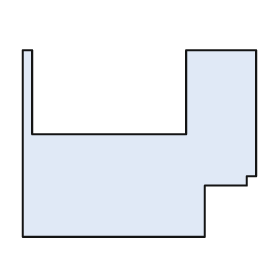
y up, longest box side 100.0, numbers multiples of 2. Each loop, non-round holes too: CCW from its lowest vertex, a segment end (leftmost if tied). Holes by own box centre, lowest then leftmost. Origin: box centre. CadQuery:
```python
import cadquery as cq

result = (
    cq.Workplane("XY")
    .moveTo(-50.0, -40.0)
    .lineTo(28.0, -40.0)
    .lineTo(28.0, -18.0)
    .lineTo(46.0, -18.0)
    .lineTo(46.0, -14.0)
    .lineTo(50.0, -14.0)
    .lineTo(50.0, 40.0)
    .lineTo(20.0, 40.0)
    .lineTo(20.0, 4.0)
    .lineTo(-46.0, 4.0)
    .lineTo(-46.0, 40.0)
    .lineTo(-50.0, 40.0)
    .close()
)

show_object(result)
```